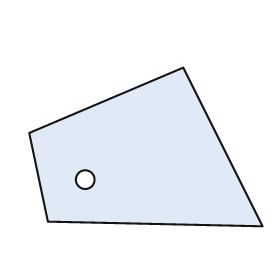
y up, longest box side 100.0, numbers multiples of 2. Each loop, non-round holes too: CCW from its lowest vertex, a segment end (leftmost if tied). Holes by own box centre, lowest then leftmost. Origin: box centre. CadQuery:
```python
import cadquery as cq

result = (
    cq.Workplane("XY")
    .moveTo(50.0, -34.0)
    .lineTo(16.0, 34.0)
    .lineTo(-50.0, 6.0)
    .lineTo(-42.0, -32.0)
    .close()
    .moveTo(-26.0, -14.0)
    .circle(4.0)
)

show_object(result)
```